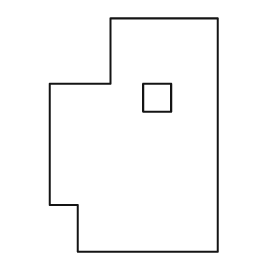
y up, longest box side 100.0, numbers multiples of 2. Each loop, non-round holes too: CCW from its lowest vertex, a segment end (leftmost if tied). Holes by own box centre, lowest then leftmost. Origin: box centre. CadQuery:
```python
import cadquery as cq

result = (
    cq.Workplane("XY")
    .moveTo(-24.0, -50.0)
    .lineTo(36.0, -50.0)
    .lineTo(36.0, 50.0)
    .lineTo(-10.0, 50.0)
    .lineTo(-10.0, 22.0)
    .lineTo(-36.0, 22.0)
    .lineTo(-36.0, -30.0)
    .lineTo(-24.0, -30.0)
    .close()
    .moveTo(4.0, 10.0)
    .lineTo(16.0, 10.0)
    .lineTo(16.0, 22.0)
    .lineTo(4.0, 22.0)
    .close()
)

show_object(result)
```